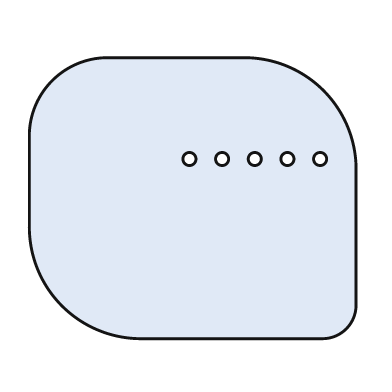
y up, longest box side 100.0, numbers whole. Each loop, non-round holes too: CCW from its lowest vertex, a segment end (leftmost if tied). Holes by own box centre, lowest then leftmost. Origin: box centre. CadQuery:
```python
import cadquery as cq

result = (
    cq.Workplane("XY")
    .moveTo(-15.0, -43.0)
    .lineTo(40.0, -43.0)
    .threePointArc((47.0, -40.0), (50.0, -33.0))
    .lineTo(50.0, 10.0)
    .threePointArc((40.0, 33.0), (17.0, 43.0))
    .lineTo(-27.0, 43.0)
    .threePointArc((-43.0, 36.0), (-50.0, 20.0))
    .lineTo(-50.0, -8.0)
    .threePointArc((-40.0, -33.0), (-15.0, -43.0))
    .close()
    .moveTo(-1.0, 12.0)
    .circle(2.0)
    .moveTo(9.0, 12.0)
    .circle(2.0)
    .moveTo(19.0, 12.0)
    .circle(2.0)
    .moveTo(29.0, 12.0)
    .circle(2.0)
    .moveTo(39.0, 12.0)
    .circle(2.0)
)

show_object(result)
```